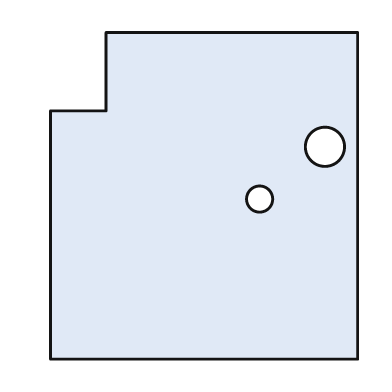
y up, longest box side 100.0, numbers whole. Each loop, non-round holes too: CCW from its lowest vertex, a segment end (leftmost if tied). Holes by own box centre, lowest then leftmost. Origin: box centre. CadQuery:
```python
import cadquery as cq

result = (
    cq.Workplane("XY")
    .moveTo(-47.0, -50.0)
    .lineTo(47.0, -50.0)
    .lineTo(47.0, 50.0)
    .lineTo(-30.0, 50.0)
    .lineTo(-30.0, 26.0)
    .lineTo(-47.0, 26.0)
    .close()
    .moveTo(17.0, -1.0)
    .circle(4.0)
    .moveTo(37.0, 15.0)
    .circle(6.0)
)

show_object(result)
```